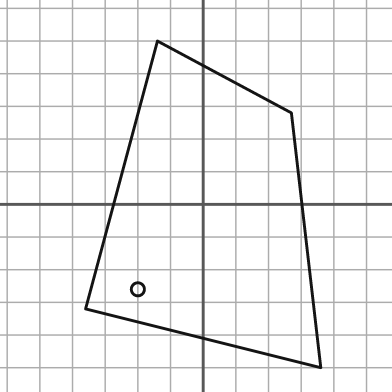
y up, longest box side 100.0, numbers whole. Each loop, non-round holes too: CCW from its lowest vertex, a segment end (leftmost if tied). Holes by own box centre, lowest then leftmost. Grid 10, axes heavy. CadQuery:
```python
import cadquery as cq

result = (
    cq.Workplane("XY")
    .moveTo(36.0, -50.0)
    .lineTo(27.0, 28.0)
    .lineTo(-14.0, 50.0)
    .lineTo(-36.0, -32.0)
    .close()
    .moveTo(-20.0, -26.0)
    .circle(2.0)
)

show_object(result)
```